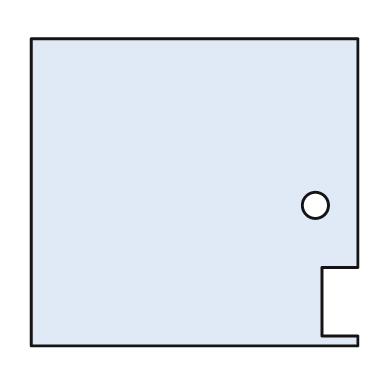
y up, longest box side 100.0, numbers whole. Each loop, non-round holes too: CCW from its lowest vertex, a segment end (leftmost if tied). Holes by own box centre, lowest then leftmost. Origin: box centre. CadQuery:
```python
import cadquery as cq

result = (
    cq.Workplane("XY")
    .moveTo(-50.0, -47.0)
    .lineTo(50.0, -47.0)
    .lineTo(50.0, -44.0)
    .lineTo(39.0, -44.0)
    .lineTo(39.0, -23.0)
    .lineTo(50.0, -23.0)
    .lineTo(50.0, 47.0)
    .lineTo(-50.0, 47.0)
    .close()
    .moveTo(37.0, -4.0)
    .circle(4.0)
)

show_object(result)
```